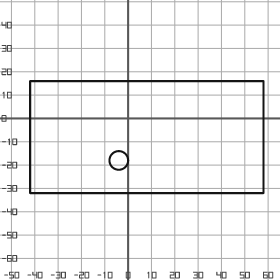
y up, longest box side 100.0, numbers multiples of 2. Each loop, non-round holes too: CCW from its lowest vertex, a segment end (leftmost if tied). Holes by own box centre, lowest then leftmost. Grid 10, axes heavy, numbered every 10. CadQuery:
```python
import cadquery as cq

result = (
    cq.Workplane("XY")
    .moveTo(-42.0, -32.0)
    .lineTo(58.0, -32.0)
    .lineTo(58.0, 16.0)
    .lineTo(-42.0, 16.0)
    .close()
    .moveTo(-4.0, -18.0)
    .circle(4.0)
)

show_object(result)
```